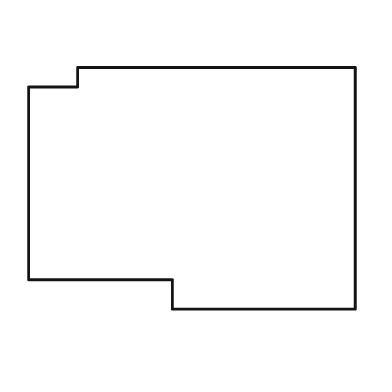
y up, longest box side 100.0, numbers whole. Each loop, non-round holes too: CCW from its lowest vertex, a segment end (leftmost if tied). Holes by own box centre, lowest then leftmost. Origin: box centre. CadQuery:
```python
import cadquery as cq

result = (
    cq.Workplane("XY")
    .moveTo(-6.0, -37.0)
    .lineTo(50.0, -37.0)
    .lineTo(50.0, 37.0)
    .lineTo(-35.0, 37.0)
    .lineTo(-35.0, 31.0)
    .lineTo(-50.0, 31.0)
    .lineTo(-50.0, -28.0)
    .lineTo(-6.0, -28.0)
    .close()
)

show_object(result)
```